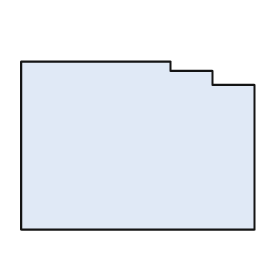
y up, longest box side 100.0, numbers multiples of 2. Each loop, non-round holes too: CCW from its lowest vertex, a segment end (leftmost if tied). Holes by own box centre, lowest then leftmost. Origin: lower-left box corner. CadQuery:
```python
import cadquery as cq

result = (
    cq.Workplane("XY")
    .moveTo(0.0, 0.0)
    .lineTo(100.0, 0.0)
    .lineTo(100.0, 62.0)
    .lineTo(82.0, 62.0)
    .lineTo(82.0, 68.0)
    .lineTo(64.0, 68.0)
    .lineTo(64.0, 72.0)
    .lineTo(0.0, 72.0)
    .close()
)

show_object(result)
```